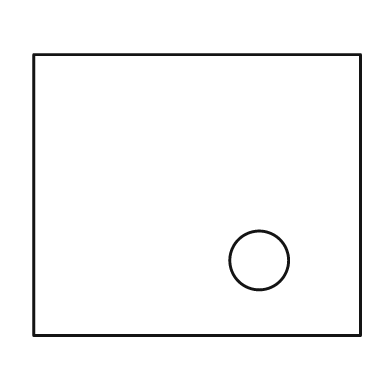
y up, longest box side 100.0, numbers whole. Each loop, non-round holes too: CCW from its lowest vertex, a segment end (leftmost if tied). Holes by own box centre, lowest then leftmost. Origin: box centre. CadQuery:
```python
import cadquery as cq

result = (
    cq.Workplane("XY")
    .moveTo(-50.0, -43.0)
    .lineTo(50.0, -43.0)
    .lineTo(50.0, 43.0)
    .lineTo(-50.0, 43.0)
    .close()
    .moveTo(19.0, -20.0)
    .circle(9.0)
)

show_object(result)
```